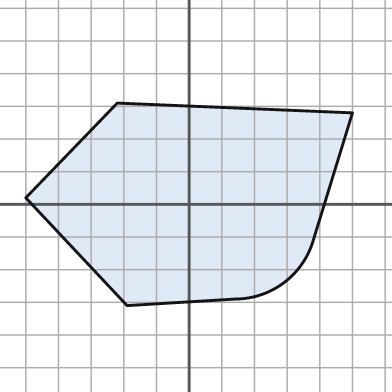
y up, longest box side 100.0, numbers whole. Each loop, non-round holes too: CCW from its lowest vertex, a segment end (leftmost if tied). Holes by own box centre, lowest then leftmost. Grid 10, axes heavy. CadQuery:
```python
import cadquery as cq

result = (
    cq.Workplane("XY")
    .moveTo(-19.0, -31.0)
    .lineTo(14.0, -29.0)
    .threePointArc((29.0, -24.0), (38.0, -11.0))
    .lineTo(50.0, 28.0)
    .lineTo(-22.0, 31.0)
    .lineTo(-50.0, 2.0)
    .close()
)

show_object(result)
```